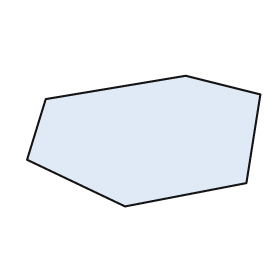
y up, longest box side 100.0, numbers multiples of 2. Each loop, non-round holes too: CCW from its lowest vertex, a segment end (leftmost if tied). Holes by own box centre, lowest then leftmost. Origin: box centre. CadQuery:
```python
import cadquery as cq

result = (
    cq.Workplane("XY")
    .moveTo(-8.0, -28.0)
    .lineTo(44.0, -18.0)
    .lineTo(50.0, 20.0)
    .lineTo(18.0, 28.0)
    .lineTo(-42.0, 18.0)
    .lineTo(-50.0, -8.0)
    .close()
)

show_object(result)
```